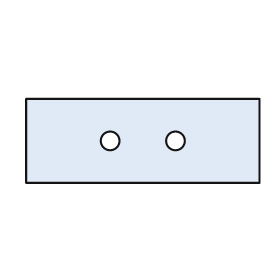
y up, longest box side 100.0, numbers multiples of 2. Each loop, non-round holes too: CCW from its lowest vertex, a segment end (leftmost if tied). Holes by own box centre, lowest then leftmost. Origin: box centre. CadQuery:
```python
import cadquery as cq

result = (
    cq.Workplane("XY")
    .moveTo(-50.0, -18.0)
    .lineTo(50.0, -18.0)
    .lineTo(50.0, 18.0)
    .lineTo(-50.0, 18.0)
    .close()
    .moveTo(-14.0, 0.0)
    .circle(4.0)
    .moveTo(14.0, 0.0)
    .circle(4.0)
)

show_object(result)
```